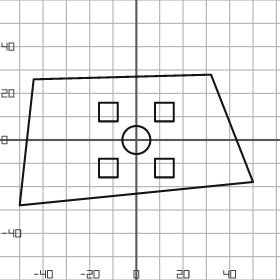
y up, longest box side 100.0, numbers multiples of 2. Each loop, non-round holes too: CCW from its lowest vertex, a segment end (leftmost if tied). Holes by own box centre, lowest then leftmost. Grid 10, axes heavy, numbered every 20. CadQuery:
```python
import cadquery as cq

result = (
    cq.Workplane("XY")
    .moveTo(-50.0, -28.0)
    .lineTo(50.0, -18.0)
    .lineTo(32.0, 28.0)
    .lineTo(-44.0, 26.0)
    .close()
    .moveTo(-16.0, -16.0)
    .lineTo(-8.0, -16.0)
    .lineTo(-8.0, -8.0)
    .lineTo(-16.0, -8.0)
    .close()
    .moveTo(8.0, -16.0)
    .lineTo(16.0, -16.0)
    .lineTo(16.0, -8.0)
    .lineTo(8.0, -8.0)
    .close()
    .moveTo(0.0, 0.0)
    .circle(6.0)
    .moveTo(-16.0, 8.0)
    .lineTo(-8.0, 8.0)
    .lineTo(-8.0, 16.0)
    .lineTo(-16.0, 16.0)
    .close()
    .moveTo(8.0, 8.0)
    .lineTo(16.0, 8.0)
    .lineTo(16.0, 16.0)
    .lineTo(8.0, 16.0)
    .close()
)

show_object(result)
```